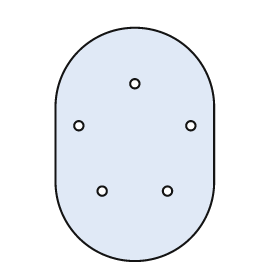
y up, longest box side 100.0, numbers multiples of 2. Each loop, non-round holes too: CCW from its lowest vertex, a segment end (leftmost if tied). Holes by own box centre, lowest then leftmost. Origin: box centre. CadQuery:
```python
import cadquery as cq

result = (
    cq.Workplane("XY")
    .moveTo(-34.0, -16.0)
    .threePointArc((0.0, -50.0), (34.0, -16.0))
    .lineTo(34.0, 16.0)
    .threePointArc((0.0, 50.0), (-34.0, 16.0))
    .close()
    .moveTo(-14.0, -20.0)
    .circle(2.0)
    .moveTo(14.0, -20.0)
    .circle(2.0)
    .moveTo(-24.0, 8.0)
    .circle(2.0)
    .moveTo(24.0, 8.0)
    .circle(2.0)
    .moveTo(0.0, 26.0)
    .circle(2.0)
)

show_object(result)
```